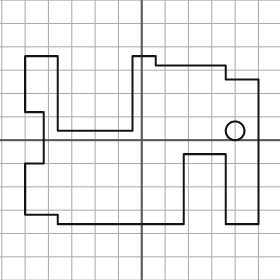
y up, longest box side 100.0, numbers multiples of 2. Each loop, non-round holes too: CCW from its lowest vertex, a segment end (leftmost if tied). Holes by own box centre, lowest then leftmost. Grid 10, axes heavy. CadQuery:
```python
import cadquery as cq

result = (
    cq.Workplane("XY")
    .moveTo(-36.0, -36.0)
    .lineTo(18.0, -36.0)
    .lineTo(18.0, -6.0)
    .lineTo(36.0, -6.0)
    .lineTo(36.0, -36.0)
    .lineTo(50.0, -36.0)
    .lineTo(50.0, 26.0)
    .lineTo(36.0, 26.0)
    .lineTo(36.0, 32.0)
    .lineTo(6.0, 32.0)
    .lineTo(6.0, 36.0)
    .lineTo(-4.0, 36.0)
    .lineTo(-4.0, 4.0)
    .lineTo(-36.0, 4.0)
    .lineTo(-36.0, 36.0)
    .lineTo(-50.0, 36.0)
    .lineTo(-50.0, 12.0)
    .lineTo(-42.0, 12.0)
    .lineTo(-42.0, -10.0)
    .lineTo(-50.0, -10.0)
    .lineTo(-50.0, -32.0)
    .lineTo(-36.0, -32.0)
    .close()
    .moveTo(40.0, 4.0)
    .circle(4.0)
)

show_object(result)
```